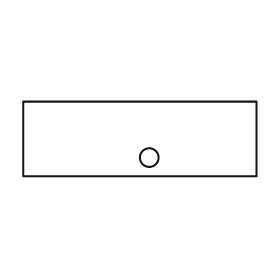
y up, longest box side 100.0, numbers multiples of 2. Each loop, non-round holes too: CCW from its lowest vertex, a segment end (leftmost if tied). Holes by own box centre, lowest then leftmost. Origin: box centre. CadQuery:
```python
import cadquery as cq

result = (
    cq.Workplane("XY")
    .moveTo(-50.0, -16.0)
    .lineTo(50.0, -16.0)
    .lineTo(50.0, 16.0)
    .lineTo(-50.0, 16.0)
    .close()
    .moveTo(4.0, -8.0)
    .circle(4.0)
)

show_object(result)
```